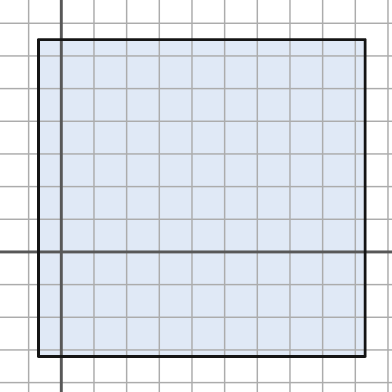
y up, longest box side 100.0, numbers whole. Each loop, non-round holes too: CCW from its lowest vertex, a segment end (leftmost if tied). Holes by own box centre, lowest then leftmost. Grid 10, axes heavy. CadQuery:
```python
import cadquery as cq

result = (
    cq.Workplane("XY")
    .moveTo(-7.0, -32.0)
    .lineTo(93.0, -32.0)
    .lineTo(93.0, 65.0)
    .lineTo(-7.0, 65.0)
    .close()
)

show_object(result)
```